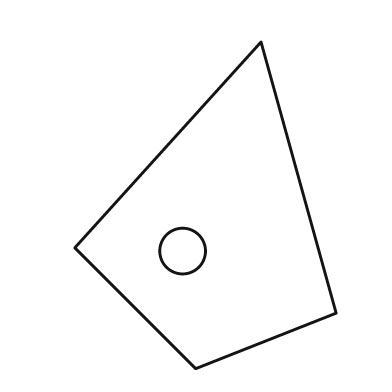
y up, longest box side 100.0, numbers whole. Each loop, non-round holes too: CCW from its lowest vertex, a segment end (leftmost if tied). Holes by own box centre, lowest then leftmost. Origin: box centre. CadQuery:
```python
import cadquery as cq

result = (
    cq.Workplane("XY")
    .moveTo(-3.0, -50.0)
    .lineTo(40.0, -33.0)
    .lineTo(17.0, 50.0)
    .lineTo(-40.0, -13.0)
    .close()
    .moveTo(-7.0, -14.0)
    .circle(7.0)
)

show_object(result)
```